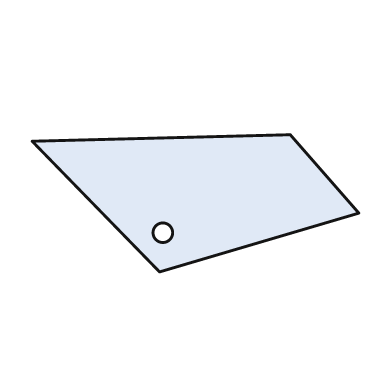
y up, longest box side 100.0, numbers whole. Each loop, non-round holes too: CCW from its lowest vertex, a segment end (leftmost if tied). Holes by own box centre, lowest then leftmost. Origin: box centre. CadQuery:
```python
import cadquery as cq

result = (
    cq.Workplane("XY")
    .moveTo(-11.0, -21.0)
    .lineTo(50.0, -3.0)
    .lineTo(29.0, 21.0)
    .lineTo(-50.0, 19.0)
    .close()
    .moveTo(-10.0, -9.0)
    .circle(3.0)
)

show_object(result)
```